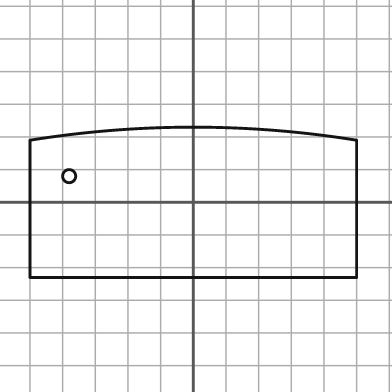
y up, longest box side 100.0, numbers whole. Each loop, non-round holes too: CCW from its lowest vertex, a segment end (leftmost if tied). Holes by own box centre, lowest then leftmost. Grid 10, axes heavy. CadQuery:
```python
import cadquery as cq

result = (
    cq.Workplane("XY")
    .moveTo(-50.0, -23.0)
    .lineTo(50.0, -23.0)
    .lineTo(50.0, 19.0)
    .threePointArc((0.0, 23.0), (-50.0, 19.0))
    .close()
    .moveTo(-38.0, 8.0)
    .circle(2.0)
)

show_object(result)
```